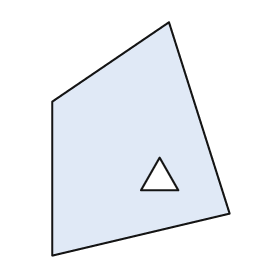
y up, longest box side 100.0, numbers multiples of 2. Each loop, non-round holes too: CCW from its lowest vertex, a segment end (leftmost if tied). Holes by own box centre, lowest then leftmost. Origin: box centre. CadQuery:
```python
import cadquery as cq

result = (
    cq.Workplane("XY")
    .moveTo(-38.0, -50.0)
    .lineTo(38.0, -32.0)
    .lineTo(12.0, 50.0)
    .lineTo(-38.0, 16.0)
    .close()
    .moveTo(0.0, -22.0)
    .lineTo(16.0, -22.0)
    .lineTo(8.0, -8.0)
    .close()
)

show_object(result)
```